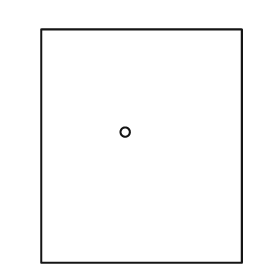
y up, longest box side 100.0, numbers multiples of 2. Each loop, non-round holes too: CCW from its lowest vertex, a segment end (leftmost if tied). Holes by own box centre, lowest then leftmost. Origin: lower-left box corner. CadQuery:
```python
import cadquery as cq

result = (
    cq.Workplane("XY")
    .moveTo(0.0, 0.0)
    .lineTo(86.0, 0.0)
    .lineTo(86.0, 100.0)
    .lineTo(0.0, 100.0)
    .close()
    .moveTo(36.0, 56.0)
    .circle(2.0)
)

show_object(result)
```